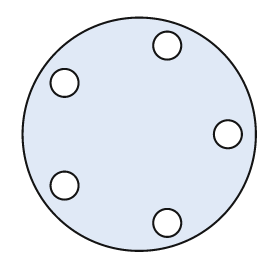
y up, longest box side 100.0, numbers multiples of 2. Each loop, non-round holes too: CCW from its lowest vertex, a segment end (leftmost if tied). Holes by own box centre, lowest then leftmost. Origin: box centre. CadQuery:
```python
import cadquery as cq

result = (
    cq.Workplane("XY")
    .moveTo(0.0, 0.0)
    .circle(50.0)
    .moveTo(12.0, -38.0)
    .circle(6.0)
    .moveTo(-32.0, -22.0)
    .circle(6.0)
    .moveTo(38.0, 0.0)
    .circle(6.0)
    .moveTo(-32.0, 22.0)
    .circle(6.0)
    .moveTo(12.0, 38.0)
    .circle(6.0)
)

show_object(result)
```